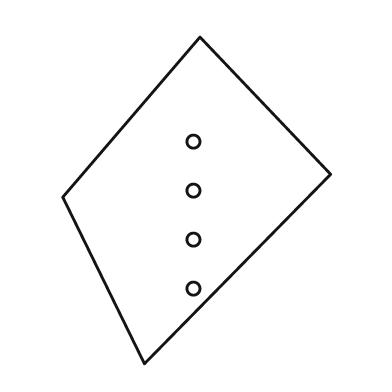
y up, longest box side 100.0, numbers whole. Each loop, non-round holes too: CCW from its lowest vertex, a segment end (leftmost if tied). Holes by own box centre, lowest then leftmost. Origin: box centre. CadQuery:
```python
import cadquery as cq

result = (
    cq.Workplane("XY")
    .moveTo(-16.0, -50.0)
    .lineTo(41.0, 8.0)
    .lineTo(1.0, 50.0)
    .lineTo(-41.0, 1.0)
    .close()
    .moveTo(-1.0, -27.0)
    .circle(2.0)
    .moveTo(-1.0, -12.0)
    .circle(2.0)
    .moveTo(-1.0, 3.0)
    .circle(2.0)
    .moveTo(-1.0, 18.0)
    .circle(2.0)
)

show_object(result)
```